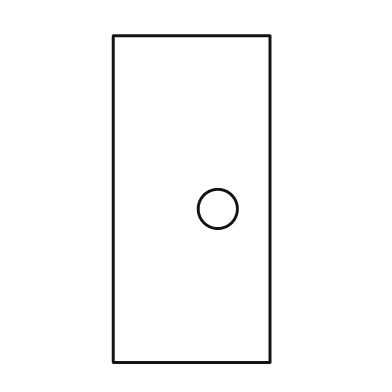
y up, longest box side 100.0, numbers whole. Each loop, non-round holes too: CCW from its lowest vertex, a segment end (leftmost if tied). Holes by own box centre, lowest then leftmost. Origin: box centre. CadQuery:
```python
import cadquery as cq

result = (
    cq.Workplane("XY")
    .moveTo(-24.0, -50.0)
    .lineTo(24.0, -50.0)
    .lineTo(24.0, 50.0)
    .lineTo(-24.0, 50.0)
    .close()
    .moveTo(8.0, -3.0)
    .circle(6.0)
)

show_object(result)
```